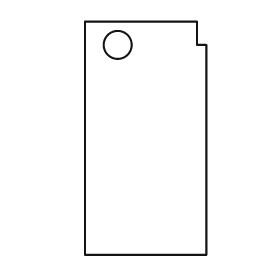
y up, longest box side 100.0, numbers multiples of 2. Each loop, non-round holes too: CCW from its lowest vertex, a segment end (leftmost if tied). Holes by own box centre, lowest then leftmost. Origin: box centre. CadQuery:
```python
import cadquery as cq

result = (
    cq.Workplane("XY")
    .moveTo(-26.0, -50.0)
    .lineTo(26.0, -50.0)
    .lineTo(26.0, 40.0)
    .lineTo(22.0, 40.0)
    .lineTo(22.0, 50.0)
    .lineTo(-26.0, 50.0)
    .close()
    .moveTo(-12.0, 40.0)
    .circle(6.0)
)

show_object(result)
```